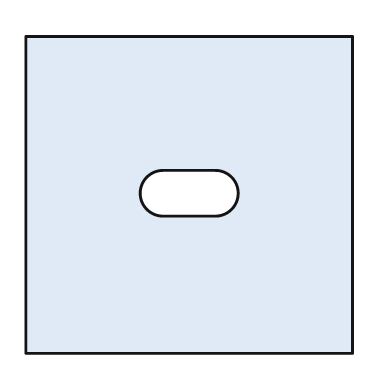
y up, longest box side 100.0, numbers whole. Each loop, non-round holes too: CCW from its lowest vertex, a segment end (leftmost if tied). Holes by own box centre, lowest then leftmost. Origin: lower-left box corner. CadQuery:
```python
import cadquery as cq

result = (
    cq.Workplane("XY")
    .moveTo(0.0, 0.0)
    .lineTo(100.0, 0.0)
    .lineTo(100.0, 97.0)
    .lineTo(0.0, 97.0)
    .close()
    .moveTo(42.0, 42.0)
    .lineTo(58.0, 42.0)
    .threePointArc((65.0, 49.0), (58.0, 56.0))
    .lineTo(42.0, 56.0)
    .threePointArc((35.0, 49.0), (42.0, 42.0))
    .close()
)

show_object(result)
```